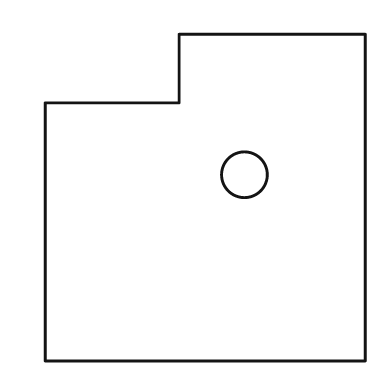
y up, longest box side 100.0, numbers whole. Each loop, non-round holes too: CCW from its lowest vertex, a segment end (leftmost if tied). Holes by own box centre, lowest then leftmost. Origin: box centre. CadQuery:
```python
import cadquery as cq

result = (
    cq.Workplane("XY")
    .moveTo(-49.0, -50.0)
    .lineTo(49.0, -50.0)
    .lineTo(49.0, 50.0)
    .lineTo(-8.0, 50.0)
    .lineTo(-8.0, 29.0)
    .lineTo(-49.0, 29.0)
    .close()
    .moveTo(12.0, 7.0)
    .circle(7.0)
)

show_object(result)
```